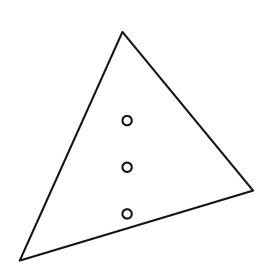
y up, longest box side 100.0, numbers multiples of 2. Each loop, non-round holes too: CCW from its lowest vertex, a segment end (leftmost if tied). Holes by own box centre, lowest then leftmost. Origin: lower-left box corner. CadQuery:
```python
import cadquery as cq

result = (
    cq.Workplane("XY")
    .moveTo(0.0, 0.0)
    .lineTo(100.0, 30.0)
    .lineTo(44.0, 98.0)
    .close()
    .moveTo(46.0, 20.0)
    .circle(2.0)
    .moveTo(46.0, 40.0)
    .circle(2.0)
    .moveTo(46.0, 60.0)
    .circle(2.0)
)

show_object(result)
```